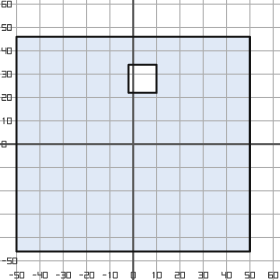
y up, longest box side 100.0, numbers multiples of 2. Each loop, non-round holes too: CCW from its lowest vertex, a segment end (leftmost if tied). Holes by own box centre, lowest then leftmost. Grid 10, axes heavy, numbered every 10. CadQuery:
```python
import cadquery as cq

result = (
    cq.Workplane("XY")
    .moveTo(-50.0, -46.0)
    .lineTo(50.0, -46.0)
    .lineTo(50.0, 46.0)
    .lineTo(-50.0, 46.0)
    .close()
    .moveTo(-2.0, 22.0)
    .lineTo(10.0, 22.0)
    .lineTo(10.0, 34.0)
    .lineTo(-2.0, 34.0)
    .close()
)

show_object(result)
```